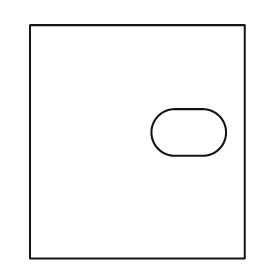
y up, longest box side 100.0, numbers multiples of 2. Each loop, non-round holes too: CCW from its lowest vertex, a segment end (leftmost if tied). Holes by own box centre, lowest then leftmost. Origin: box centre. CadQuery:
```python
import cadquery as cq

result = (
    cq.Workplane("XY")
    .moveTo(-46.0, -50.0)
    .lineTo(46.0, -50.0)
    .lineTo(46.0, 50.0)
    .lineTo(-46.0, 50.0)
    .close()
    .moveTo(16.0, -6.0)
    .lineTo(28.0, -6.0)
    .threePointArc((38.0, 4.0), (28.0, 14.0))
    .lineTo(16.0, 14.0)
    .threePointArc((6.0, 4.0), (16.0, -6.0))
    .close()
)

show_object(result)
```